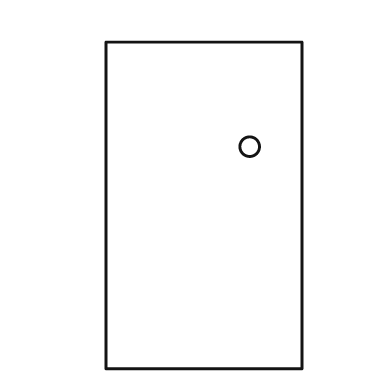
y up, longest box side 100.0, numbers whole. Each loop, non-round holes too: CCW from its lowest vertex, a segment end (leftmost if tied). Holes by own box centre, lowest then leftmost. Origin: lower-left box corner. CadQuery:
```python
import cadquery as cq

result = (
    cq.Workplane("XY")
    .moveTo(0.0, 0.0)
    .lineTo(60.0, 0.0)
    .lineTo(60.0, 100.0)
    .lineTo(0.0, 100.0)
    .close()
    .moveTo(44.0, 68.0)
    .circle(3.0)
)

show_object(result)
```